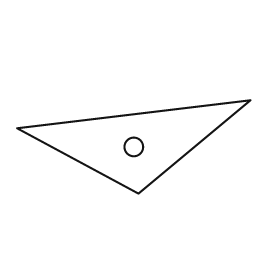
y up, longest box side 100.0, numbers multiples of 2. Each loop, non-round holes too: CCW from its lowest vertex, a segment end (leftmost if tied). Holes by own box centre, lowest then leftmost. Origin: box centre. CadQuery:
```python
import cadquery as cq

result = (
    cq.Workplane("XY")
    .moveTo(2.0, -20.0)
    .lineTo(50.0, 20.0)
    .lineTo(-50.0, 8.0)
    .close()
    .moveTo(0.0, 0.0)
    .circle(4.0)
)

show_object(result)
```